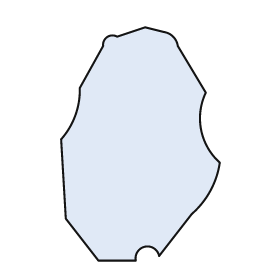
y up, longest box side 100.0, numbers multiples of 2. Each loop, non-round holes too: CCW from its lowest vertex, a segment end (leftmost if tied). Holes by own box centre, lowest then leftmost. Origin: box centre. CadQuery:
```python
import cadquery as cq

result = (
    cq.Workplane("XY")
    .moveTo(-18.0, -50.0)
    .lineTo(-2.0, -50.0)
    .threePointArc((2.0, -44.0), (8.0, -48.0))
    .lineTo(22.0, -30.0)
    .threePointArc((30.0, -20.0), (34.0, -8.0))
    .threePointArc((26.0, 6.0), (28.0, 22.0))
    .lineTo(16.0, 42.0)
    .threePointArc((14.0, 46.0), (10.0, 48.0))
    .lineTo(2.0, 50.0)
    .lineTo(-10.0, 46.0)
    .threePointArc((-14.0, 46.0), (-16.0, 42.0))
    .lineTo(-26.0, 24.0)
    .threePointArc((-28.0, 12.0), (-34.0, 2.0))
    .lineTo(-32.0, -32.0)
    .close()
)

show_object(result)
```